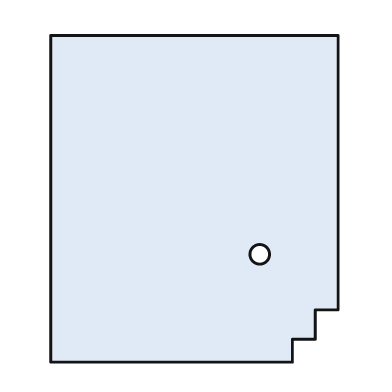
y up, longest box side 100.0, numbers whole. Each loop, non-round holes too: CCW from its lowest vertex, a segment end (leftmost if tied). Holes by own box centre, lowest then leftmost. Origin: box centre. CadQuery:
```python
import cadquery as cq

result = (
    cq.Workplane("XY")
    .moveTo(-44.0, -50.0)
    .lineTo(30.0, -50.0)
    .lineTo(30.0, -43.0)
    .lineTo(37.0, -43.0)
    .lineTo(37.0, -34.0)
    .lineTo(44.0, -34.0)
    .lineTo(44.0, 50.0)
    .lineTo(-44.0, 50.0)
    .close()
    .moveTo(20.0, -17.0)
    .circle(3.0)
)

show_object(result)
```